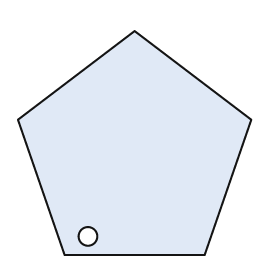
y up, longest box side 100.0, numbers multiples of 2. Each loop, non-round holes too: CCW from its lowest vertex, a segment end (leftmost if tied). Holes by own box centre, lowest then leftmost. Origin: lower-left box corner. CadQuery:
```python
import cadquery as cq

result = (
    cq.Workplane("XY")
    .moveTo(20.0, 0.0)
    .lineTo(80.0, 0.0)
    .lineTo(100.0, 58.0)
    .lineTo(50.0, 96.0)
    .lineTo(0.0, 58.0)
    .close()
    .moveTo(30.0, 8.0)
    .circle(4.0)
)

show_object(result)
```